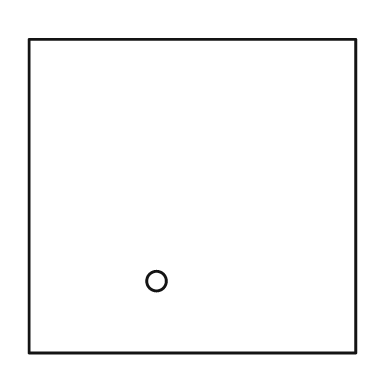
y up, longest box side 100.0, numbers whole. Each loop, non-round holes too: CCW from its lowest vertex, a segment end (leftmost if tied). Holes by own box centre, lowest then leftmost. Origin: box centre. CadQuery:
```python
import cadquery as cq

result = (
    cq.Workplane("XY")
    .moveTo(-50.0, -48.0)
    .lineTo(50.0, -48.0)
    .lineTo(50.0, 48.0)
    .lineTo(-50.0, 48.0)
    .close()
    .moveTo(-11.0, -26.0)
    .circle(3.0)
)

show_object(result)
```